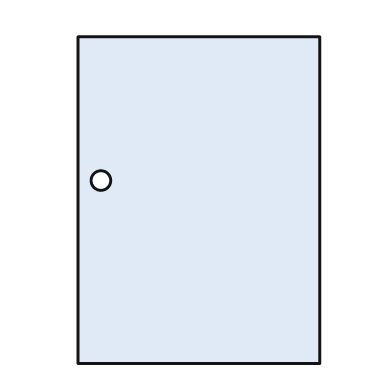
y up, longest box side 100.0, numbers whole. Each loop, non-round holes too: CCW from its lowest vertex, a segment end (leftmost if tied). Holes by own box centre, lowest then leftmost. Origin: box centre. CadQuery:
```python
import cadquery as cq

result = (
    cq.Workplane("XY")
    .moveTo(-37.0, -50.0)
    .lineTo(37.0, -50.0)
    .lineTo(37.0, 50.0)
    .lineTo(-37.0, 50.0)
    .close()
    .moveTo(-30.0, 6.0)
    .circle(3.0)
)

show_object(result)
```